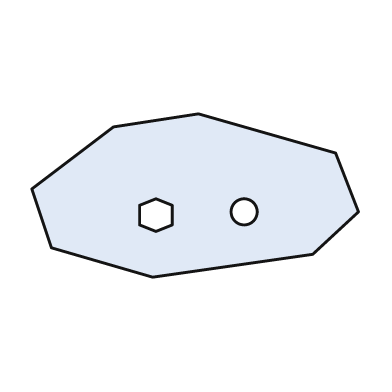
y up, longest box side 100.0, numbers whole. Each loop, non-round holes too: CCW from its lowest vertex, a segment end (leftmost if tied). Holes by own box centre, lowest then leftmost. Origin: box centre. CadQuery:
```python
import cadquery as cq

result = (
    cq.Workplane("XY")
    .moveTo(-13.0, -25.0)
    .lineTo(36.0, -18.0)
    .lineTo(50.0, -5.0)
    .lineTo(43.0, 13.0)
    .lineTo(1.0, 25.0)
    .lineTo(-25.0, 21.0)
    .lineTo(-50.0, 2.0)
    .lineTo(-44.0, -16.0)
    .close()
    .moveTo(-12.0, -11.0)
    .lineTo(-7.0, -9.0)
    .lineTo(-7.0, -3.0)
    .lineTo(-12.0, -1.0)
    .lineTo(-17.0, -3.0)
    .lineTo(-17.0, -9.0)
    .close()
    .moveTo(15.0, -5.0)
    .circle(4.0)
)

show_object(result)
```